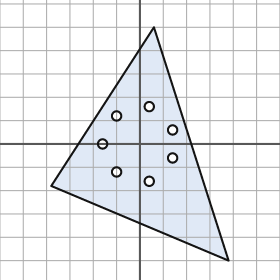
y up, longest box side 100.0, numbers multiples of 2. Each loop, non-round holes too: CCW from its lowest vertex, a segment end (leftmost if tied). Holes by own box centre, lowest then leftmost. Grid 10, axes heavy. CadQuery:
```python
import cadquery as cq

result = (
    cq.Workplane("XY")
    .moveTo(38.0, -50.0)
    .lineTo(6.0, 50.0)
    .lineTo(-38.0, -18.0)
    .close()
    .moveTo(4.0, -16.0)
    .circle(2.0)
    .moveTo(-10.0, -12.0)
    .circle(2.0)
    .moveTo(14.0, -6.0)
    .circle(2.0)
    .moveTo(-16.0, 0.0)
    .circle(2.0)
    .moveTo(14.0, 6.0)
    .circle(2.0)
    .moveTo(-10.0, 12.0)
    .circle(2.0)
    .moveTo(4.0, 16.0)
    .circle(2.0)
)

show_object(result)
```